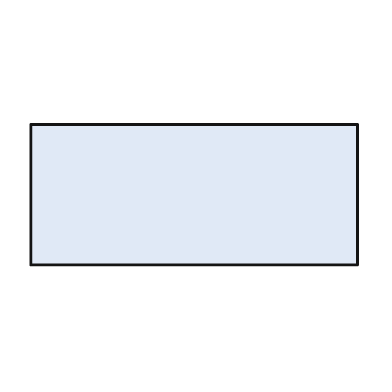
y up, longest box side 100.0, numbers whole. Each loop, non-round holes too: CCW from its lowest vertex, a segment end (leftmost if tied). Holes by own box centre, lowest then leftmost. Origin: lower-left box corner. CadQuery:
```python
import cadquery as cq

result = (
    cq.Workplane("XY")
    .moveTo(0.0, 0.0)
    .lineTo(100.0, 0.0)
    .lineTo(100.0, 43.0)
    .lineTo(0.0, 43.0)
    .close()
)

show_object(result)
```